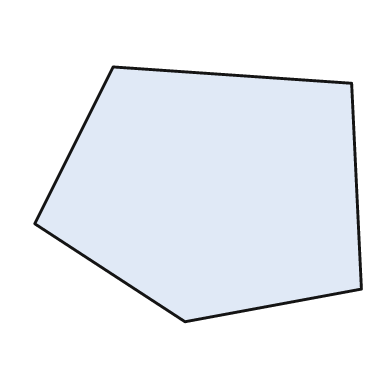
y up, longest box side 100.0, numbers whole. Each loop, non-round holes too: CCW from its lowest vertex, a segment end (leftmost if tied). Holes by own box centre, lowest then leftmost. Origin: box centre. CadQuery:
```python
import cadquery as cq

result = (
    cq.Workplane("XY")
    .moveTo(-4.0, -39.0)
    .lineTo(50.0, -29.0)
    .lineTo(47.0, 34.0)
    .lineTo(-26.0, 39.0)
    .lineTo(-50.0, -9.0)
    .close()
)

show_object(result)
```